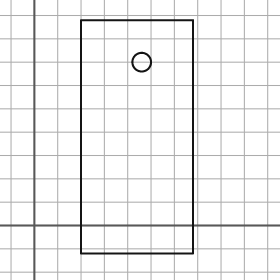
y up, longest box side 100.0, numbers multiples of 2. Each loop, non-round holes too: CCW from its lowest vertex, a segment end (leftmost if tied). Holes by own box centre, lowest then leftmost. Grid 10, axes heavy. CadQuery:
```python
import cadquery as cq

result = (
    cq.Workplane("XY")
    .moveTo(20.0, -12.0)
    .lineTo(68.0, -12.0)
    .lineTo(68.0, 88.0)
    .lineTo(20.0, 88.0)
    .close()
    .moveTo(46.0, 70.0)
    .circle(4.0)
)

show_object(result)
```